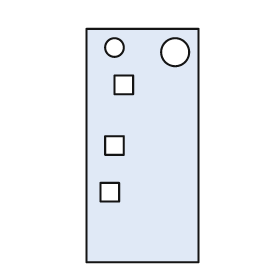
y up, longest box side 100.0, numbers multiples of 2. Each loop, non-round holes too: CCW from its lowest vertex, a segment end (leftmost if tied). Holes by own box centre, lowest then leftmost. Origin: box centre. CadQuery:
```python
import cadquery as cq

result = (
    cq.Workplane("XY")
    .moveTo(-24.0, -50.0)
    .lineTo(24.0, -50.0)
    .lineTo(24.0, 50.0)
    .lineTo(-24.0, 50.0)
    .close()
    .moveTo(-18.0, -24.0)
    .lineTo(-10.0, -24.0)
    .lineTo(-10.0, -16.0)
    .lineTo(-18.0, -16.0)
    .close()
    .moveTo(-16.0, -4.0)
    .lineTo(-8.0, -4.0)
    .lineTo(-8.0, 4.0)
    .lineTo(-16.0, 4.0)
    .close()
    .moveTo(-12.0, 22.0)
    .lineTo(-4.0, 22.0)
    .lineTo(-4.0, 30.0)
    .lineTo(-12.0, 30.0)
    .close()
    .moveTo(14.0, 40.0)
    .circle(6.0)
    .moveTo(-12.0, 42.0)
    .circle(4.0)
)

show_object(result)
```